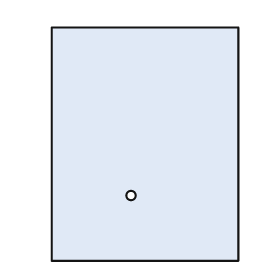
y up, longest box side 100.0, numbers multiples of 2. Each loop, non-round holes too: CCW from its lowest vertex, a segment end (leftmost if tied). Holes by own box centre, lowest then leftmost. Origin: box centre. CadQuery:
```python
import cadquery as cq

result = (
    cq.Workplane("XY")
    .moveTo(-40.0, -50.0)
    .lineTo(40.0, -50.0)
    .lineTo(40.0, 50.0)
    .lineTo(-40.0, 50.0)
    .close()
    .moveTo(-6.0, -22.0)
    .circle(2.0)
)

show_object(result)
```